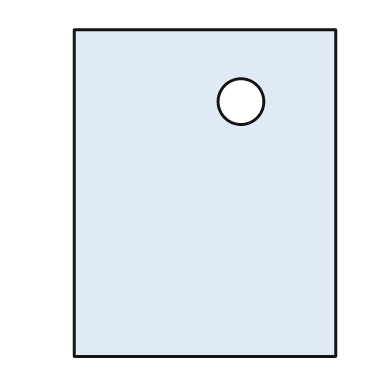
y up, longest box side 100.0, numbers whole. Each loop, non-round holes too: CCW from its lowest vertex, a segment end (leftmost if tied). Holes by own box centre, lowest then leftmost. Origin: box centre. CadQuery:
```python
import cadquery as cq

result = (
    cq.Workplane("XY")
    .moveTo(-40.0, -50.0)
    .lineTo(40.0, -50.0)
    .lineTo(40.0, 50.0)
    .lineTo(-40.0, 50.0)
    .close()
    .moveTo(11.0, 28.0)
    .circle(7.0)
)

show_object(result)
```